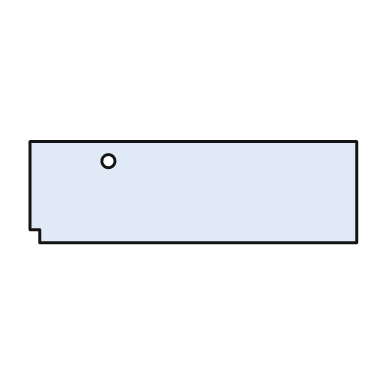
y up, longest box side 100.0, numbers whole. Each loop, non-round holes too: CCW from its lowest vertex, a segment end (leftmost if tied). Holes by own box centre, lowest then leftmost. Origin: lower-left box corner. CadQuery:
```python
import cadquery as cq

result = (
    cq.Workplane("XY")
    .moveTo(3.0, 0.0)
    .lineTo(100.0, 0.0)
    .lineTo(100.0, 31.0)
    .lineTo(0.0, 31.0)
    .lineTo(0.0, 4.0)
    .lineTo(3.0, 4.0)
    .close()
    .moveTo(24.0, 25.0)
    .circle(2.0)
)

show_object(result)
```